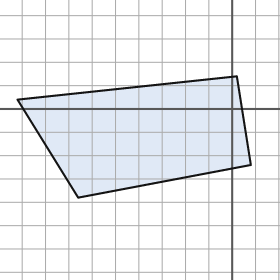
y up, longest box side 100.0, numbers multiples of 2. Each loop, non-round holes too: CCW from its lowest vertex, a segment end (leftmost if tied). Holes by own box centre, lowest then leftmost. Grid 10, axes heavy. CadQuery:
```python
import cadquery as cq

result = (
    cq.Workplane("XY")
    .moveTo(-66.0, -38.0)
    .lineTo(8.0, -24.0)
    .lineTo(2.0, 14.0)
    .lineTo(-92.0, 4.0)
    .close()
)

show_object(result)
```